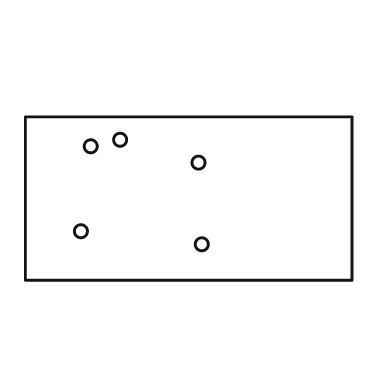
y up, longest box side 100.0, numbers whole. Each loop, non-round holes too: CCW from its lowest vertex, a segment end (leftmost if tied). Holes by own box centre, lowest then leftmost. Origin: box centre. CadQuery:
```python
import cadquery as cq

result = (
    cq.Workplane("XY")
    .moveTo(-50.0, -25.0)
    .lineTo(50.0, -25.0)
    .lineTo(50.0, 25.0)
    .lineTo(-50.0, 25.0)
    .close()
    .moveTo(4.0, -14.0)
    .circle(2.0)
    .moveTo(-33.0, -10.0)
    .circle(2.0)
    .moveTo(3.0, 11.0)
    .circle(2.0)
    .moveTo(-30.0, 16.0)
    .circle(2.0)
    .moveTo(-21.0, 18.0)
    .circle(2.0)
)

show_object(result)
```